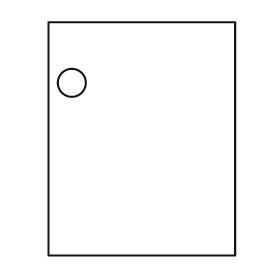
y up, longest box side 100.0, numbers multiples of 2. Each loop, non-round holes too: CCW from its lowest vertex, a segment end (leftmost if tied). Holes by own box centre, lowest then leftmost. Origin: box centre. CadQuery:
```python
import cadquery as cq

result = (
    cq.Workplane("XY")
    .moveTo(-40.0, -50.0)
    .lineTo(40.0, -50.0)
    .lineTo(40.0, 50.0)
    .lineTo(-40.0, 50.0)
    .close()
    .moveTo(-30.0, 24.0)
    .circle(6.0)
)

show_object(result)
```